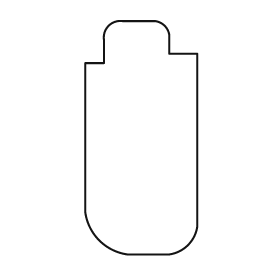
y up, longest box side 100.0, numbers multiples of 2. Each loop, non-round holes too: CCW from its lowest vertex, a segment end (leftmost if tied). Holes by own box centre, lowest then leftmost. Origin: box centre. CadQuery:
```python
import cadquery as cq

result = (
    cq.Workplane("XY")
    .moveTo(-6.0, -50.0)
    .lineTo(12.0, -50.0)
    .threePointArc((20.0, -46.0), (24.0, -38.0))
    .lineTo(24.0, 36.0)
    .lineTo(12.0, 36.0)
    .lineTo(12.0, 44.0)
    .threePointArc((10.0, 48.0), (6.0, 50.0))
    .lineTo(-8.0, 50.0)
    .threePointArc((-14.0, 48.0), (-16.0, 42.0))
    .lineTo(-16.0, 32.0)
    .lineTo(-24.0, 32.0)
    .lineTo(-24.0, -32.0)
    .threePointArc((-18.0, -44.0), (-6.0, -50.0))
    .close()
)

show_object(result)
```